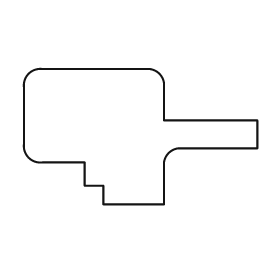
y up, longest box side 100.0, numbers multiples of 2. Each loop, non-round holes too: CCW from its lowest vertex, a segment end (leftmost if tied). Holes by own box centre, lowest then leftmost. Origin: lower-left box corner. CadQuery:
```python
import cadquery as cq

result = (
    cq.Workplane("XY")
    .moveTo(34.0, 0.0)
    .lineTo(60.0, 0.0)
    .lineTo(60.0, 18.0)
    .threePointArc((62.0, 22.0), (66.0, 24.0))
    .lineTo(100.0, 24.0)
    .lineTo(100.0, 36.0)
    .lineTo(60.0, 36.0)
    .lineTo(60.0, 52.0)
    .threePointArc((58.0, 56.0), (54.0, 58.0))
    .lineTo(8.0, 58.0)
    .threePointArc((2.0, 56.0), (0.0, 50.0))
    .lineTo(0.0, 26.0)
    .threePointArc((2.0, 20.0), (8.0, 18.0))
    .lineTo(26.0, 18.0)
    .lineTo(26.0, 8.0)
    .lineTo(34.0, 8.0)
    .close()
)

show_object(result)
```